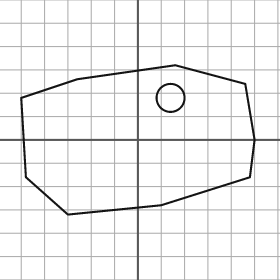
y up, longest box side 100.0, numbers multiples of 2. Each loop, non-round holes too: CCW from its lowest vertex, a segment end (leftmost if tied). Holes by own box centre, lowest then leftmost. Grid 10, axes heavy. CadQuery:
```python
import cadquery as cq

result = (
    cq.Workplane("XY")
    .moveTo(-30.0, -32.0)
    .lineTo(10.0, -28.0)
    .lineTo(48.0, -16.0)
    .lineTo(50.0, 0.0)
    .lineTo(46.0, 24.0)
    .lineTo(16.0, 32.0)
    .lineTo(-26.0, 26.0)
    .lineTo(-50.0, 18.0)
    .lineTo(-48.0, -16.0)
    .close()
    .moveTo(14.0, 18.0)
    .circle(6.0)
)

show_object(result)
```